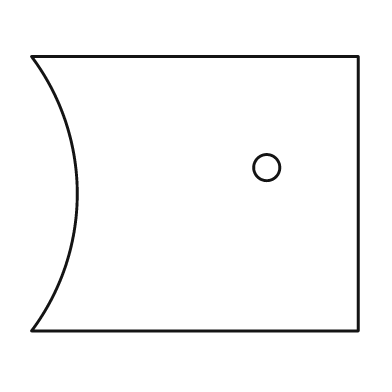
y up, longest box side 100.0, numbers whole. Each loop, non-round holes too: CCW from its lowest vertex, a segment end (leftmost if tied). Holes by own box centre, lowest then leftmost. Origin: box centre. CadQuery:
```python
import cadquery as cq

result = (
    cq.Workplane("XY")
    .moveTo(-50.0, -42.0)
    .lineTo(50.0, -42.0)
    .lineTo(50.0, 42.0)
    .lineTo(-50.0, 42.0)
    .threePointArc((-36.0, 0.0), (-50.0, -42.0))
    .close()
    .moveTo(22.0, 8.0)
    .circle(4.0)
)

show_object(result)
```